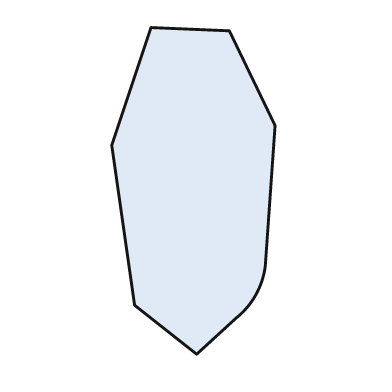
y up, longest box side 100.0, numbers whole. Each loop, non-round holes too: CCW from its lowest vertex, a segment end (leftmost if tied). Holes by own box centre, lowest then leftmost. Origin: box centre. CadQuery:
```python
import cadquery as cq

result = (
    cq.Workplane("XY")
    .moveTo(1.0, -50.0)
    .lineTo(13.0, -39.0)
    .threePointArc((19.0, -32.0), (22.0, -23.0))
    .lineTo(25.0, 20.0)
    .lineTo(11.0, 49.0)
    .lineTo(-13.0, 50.0)
    .lineTo(-25.0, 14.0)
    .lineTo(-18.0, -35.0)
    .close()
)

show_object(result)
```